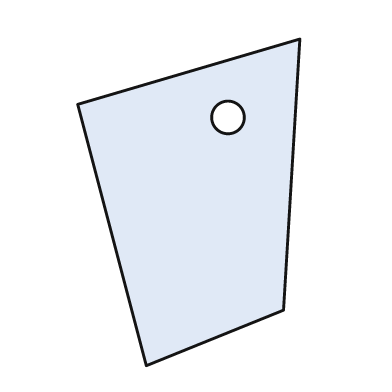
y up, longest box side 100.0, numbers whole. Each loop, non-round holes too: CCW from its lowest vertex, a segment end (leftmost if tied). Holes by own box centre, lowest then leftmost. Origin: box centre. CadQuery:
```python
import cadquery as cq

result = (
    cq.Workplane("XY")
    .moveTo(-13.0, -50.0)
    .lineTo(29.0, -33.0)
    .lineTo(34.0, 50.0)
    .lineTo(-34.0, 30.0)
    .close()
    .moveTo(12.0, 26.0)
    .circle(5.0)
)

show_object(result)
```